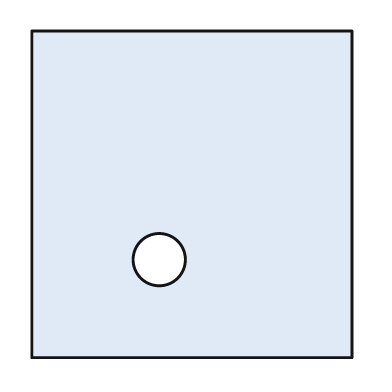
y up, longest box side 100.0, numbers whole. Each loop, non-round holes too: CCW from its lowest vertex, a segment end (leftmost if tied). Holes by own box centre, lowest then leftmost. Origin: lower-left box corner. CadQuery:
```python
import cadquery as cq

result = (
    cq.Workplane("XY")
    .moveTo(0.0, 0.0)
    .lineTo(98.0, 0.0)
    .lineTo(98.0, 100.0)
    .lineTo(0.0, 100.0)
    .close()
    .moveTo(39.0, 30.0)
    .circle(8.0)
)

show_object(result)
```